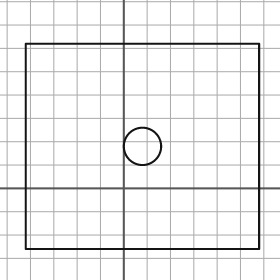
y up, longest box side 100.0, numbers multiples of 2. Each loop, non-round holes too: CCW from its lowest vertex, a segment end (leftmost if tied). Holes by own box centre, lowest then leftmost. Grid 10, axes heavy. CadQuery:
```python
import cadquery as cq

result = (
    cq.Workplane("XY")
    .moveTo(-42.0, -26.0)
    .lineTo(58.0, -26.0)
    .lineTo(58.0, 62.0)
    .lineTo(-42.0, 62.0)
    .close()
    .moveTo(8.0, 18.0)
    .circle(8.0)
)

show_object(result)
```